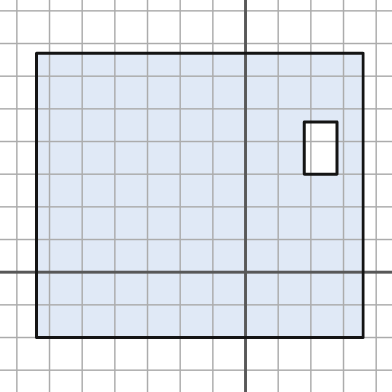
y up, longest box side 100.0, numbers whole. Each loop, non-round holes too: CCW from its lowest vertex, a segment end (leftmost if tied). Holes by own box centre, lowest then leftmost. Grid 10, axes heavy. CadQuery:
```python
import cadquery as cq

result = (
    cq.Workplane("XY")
    .moveTo(-64.0, -20.0)
    .lineTo(36.0, -20.0)
    .lineTo(36.0, 67.0)
    .lineTo(-64.0, 67.0)
    .close()
    .moveTo(18.0, 30.0)
    .lineTo(28.0, 30.0)
    .lineTo(28.0, 46.0)
    .lineTo(18.0, 46.0)
    .close()
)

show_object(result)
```